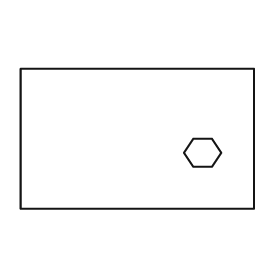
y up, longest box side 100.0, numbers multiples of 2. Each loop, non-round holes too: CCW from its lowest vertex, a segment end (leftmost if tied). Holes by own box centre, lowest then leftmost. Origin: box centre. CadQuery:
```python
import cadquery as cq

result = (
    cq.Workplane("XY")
    .moveTo(-50.0, -30.0)
    .lineTo(50.0, -30.0)
    .lineTo(50.0, 30.0)
    .lineTo(-50.0, 30.0)
    .close()
    .moveTo(24.0, -12.0)
    .lineTo(32.0, -12.0)
    .lineTo(36.0, -6.0)
    .lineTo(32.0, 0.0)
    .lineTo(24.0, 0.0)
    .lineTo(20.0, -6.0)
    .close()
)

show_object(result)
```